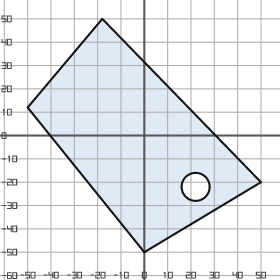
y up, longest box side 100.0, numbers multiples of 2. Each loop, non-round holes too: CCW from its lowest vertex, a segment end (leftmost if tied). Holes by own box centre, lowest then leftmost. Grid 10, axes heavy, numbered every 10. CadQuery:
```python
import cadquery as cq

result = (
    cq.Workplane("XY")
    .moveTo(0.0, -50.0)
    .lineTo(50.0, -20.0)
    .lineTo(-18.0, 50.0)
    .lineTo(-50.0, 12.0)
    .close()
    .moveTo(22.0, -22.0)
    .circle(6.0)
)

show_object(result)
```